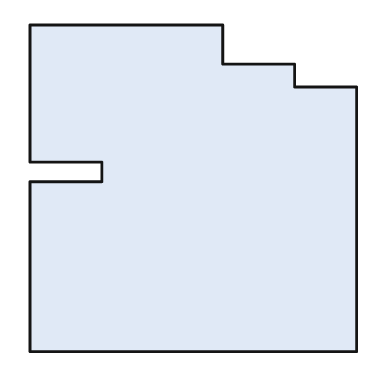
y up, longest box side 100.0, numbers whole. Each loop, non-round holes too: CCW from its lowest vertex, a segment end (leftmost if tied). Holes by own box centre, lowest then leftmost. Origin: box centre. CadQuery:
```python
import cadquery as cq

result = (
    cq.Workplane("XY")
    .moveTo(-50.0, -50.0)
    .lineTo(50.0, -50.0)
    .lineTo(50.0, 31.0)
    .lineTo(31.0, 31.0)
    .lineTo(31.0, 38.0)
    .lineTo(9.0, 38.0)
    .lineTo(9.0, 50.0)
    .lineTo(-50.0, 50.0)
    .lineTo(-50.0, 8.0)
    .lineTo(-28.0, 8.0)
    .lineTo(-28.0, 2.0)
    .lineTo(-50.0, 2.0)
    .close()
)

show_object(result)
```